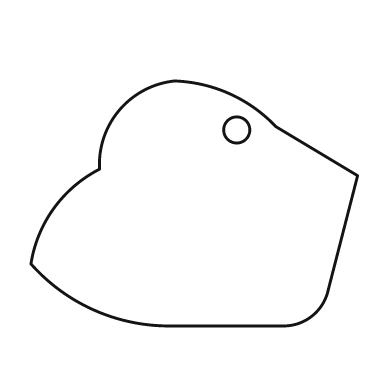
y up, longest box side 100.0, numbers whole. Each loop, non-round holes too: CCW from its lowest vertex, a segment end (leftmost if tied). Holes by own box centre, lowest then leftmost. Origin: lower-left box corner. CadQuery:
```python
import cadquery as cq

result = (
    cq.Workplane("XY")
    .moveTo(42.0, 0.0)
    .lineTo(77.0, 0.0)
    .threePointArc((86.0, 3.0), (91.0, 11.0))
    .lineTo(100.0, 46.0)
    .lineTo(75.0, 61.0)
    .threePointArc((61.0, 71.0), (44.0, 75.0))
    .threePointArc((27.0, 66.0), (21.0, 48.0))
    .threePointArc((7.0, 36.0), (0.0, 19.0))
    .threePointArc((19.0, 5.0), (42.0, 0.0))
    .close()
    .moveTo(63.0, 60.0)
    .circle(4.0)
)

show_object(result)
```